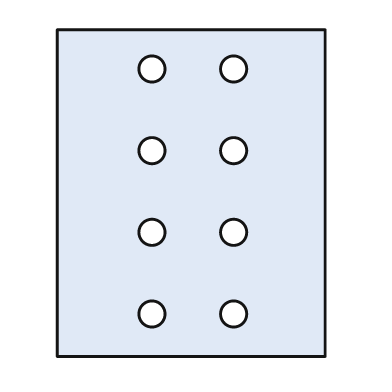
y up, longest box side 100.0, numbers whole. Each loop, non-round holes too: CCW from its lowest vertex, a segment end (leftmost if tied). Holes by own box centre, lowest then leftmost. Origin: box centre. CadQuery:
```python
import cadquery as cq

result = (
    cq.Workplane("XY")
    .moveTo(-41.0, -50.0)
    .lineTo(41.0, -50.0)
    .lineTo(41.0, 50.0)
    .lineTo(-41.0, 50.0)
    .close()
    .moveTo(-12.0, -37.0)
    .circle(4.0)
    .moveTo(13.0, -37.0)
    .circle(4.0)
    .moveTo(-12.0, -12.0)
    .circle(4.0)
    .moveTo(13.0, -12.0)
    .circle(4.0)
    .moveTo(-12.0, 13.0)
    .circle(4.0)
    .moveTo(13.0, 13.0)
    .circle(4.0)
    .moveTo(-12.0, 38.0)
    .circle(4.0)
    .moveTo(13.0, 38.0)
    .circle(4.0)
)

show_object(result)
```